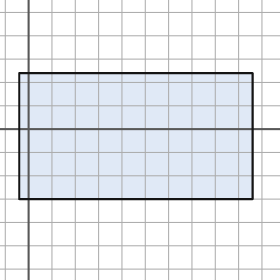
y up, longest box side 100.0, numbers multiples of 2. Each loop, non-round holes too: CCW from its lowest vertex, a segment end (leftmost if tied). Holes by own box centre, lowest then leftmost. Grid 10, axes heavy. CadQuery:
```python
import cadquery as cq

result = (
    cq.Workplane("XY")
    .moveTo(-4.0, -30.0)
    .lineTo(96.0, -30.0)
    .lineTo(96.0, 24.0)
    .lineTo(-4.0, 24.0)
    .close()
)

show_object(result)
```